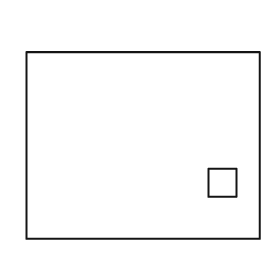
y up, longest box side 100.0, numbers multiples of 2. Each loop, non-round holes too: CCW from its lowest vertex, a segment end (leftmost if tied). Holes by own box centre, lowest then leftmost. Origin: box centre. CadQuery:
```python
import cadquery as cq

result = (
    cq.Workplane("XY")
    .moveTo(-50.0, -40.0)
    .lineTo(50.0, -40.0)
    .lineTo(50.0, 40.0)
    .lineTo(-50.0, 40.0)
    .close()
    .moveTo(28.0, -22.0)
    .lineTo(40.0, -22.0)
    .lineTo(40.0, -10.0)
    .lineTo(28.0, -10.0)
    .close()
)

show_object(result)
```